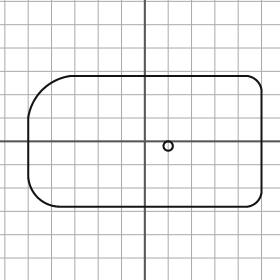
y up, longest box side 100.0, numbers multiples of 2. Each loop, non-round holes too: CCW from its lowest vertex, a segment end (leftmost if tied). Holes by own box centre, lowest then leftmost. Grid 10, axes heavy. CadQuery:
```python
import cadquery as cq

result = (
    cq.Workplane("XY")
    .moveTo(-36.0, -28.0)
    .lineTo(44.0, -28.0)
    .threePointArc((48.0, -26.0), (50.0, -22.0))
    .lineTo(50.0, 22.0)
    .threePointArc((48.0, 26.0), (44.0, 28.0))
    .lineTo(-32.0, 28.0)
    .threePointArc((-44.0, 22.0), (-50.0, 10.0))
    .lineTo(-50.0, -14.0)
    .threePointArc((-46.0, -24.0), (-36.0, -28.0))
    .close()
    .moveTo(10.0, -2.0)
    .circle(2.0)
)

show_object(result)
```